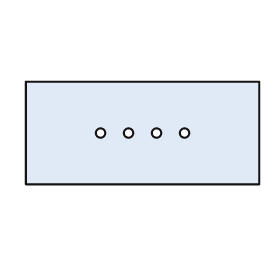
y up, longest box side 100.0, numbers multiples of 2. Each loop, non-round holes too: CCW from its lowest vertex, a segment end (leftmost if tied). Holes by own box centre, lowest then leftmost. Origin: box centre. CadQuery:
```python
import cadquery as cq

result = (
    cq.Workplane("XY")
    .moveTo(-50.0, -22.0)
    .lineTo(50.0, -22.0)
    .lineTo(50.0, 22.0)
    .lineTo(-50.0, 22.0)
    .close()
    .moveTo(-18.0, 0.0)
    .circle(2.0)
    .moveTo(-6.0, 0.0)
    .circle(2.0)
    .moveTo(6.0, 0.0)
    .circle(2.0)
    .moveTo(18.0, 0.0)
    .circle(2.0)
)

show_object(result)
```